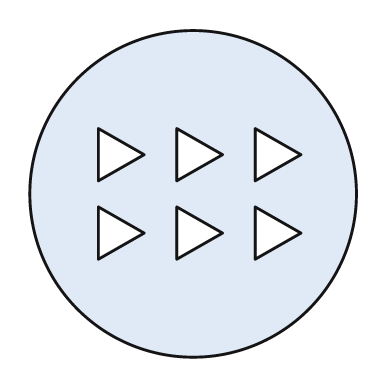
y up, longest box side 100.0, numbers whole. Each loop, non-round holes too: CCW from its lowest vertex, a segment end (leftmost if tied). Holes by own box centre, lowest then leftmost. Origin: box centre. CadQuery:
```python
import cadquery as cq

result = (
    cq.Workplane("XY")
    .moveTo(0.0, 0.0)
    .circle(50.0)
    .moveTo(-29.0, -20.0)
    .lineTo(-15.0, -12.0)
    .lineTo(-29.0, -4.0)
    .close()
    .moveTo(-5.0, -20.0)
    .lineTo(9.0, -12.0)
    .lineTo(-5.0, -4.0)
    .close()
    .moveTo(19.0, -20.0)
    .lineTo(33.0, -12.0)
    .lineTo(19.0, -4.0)
    .close()
    .moveTo(-29.0, 4.0)
    .lineTo(-15.0, 12.0)
    .lineTo(-29.0, 20.0)
    .close()
    .moveTo(-5.0, 4.0)
    .lineTo(9.0, 12.0)
    .lineTo(-5.0, 20.0)
    .close()
    .moveTo(19.0, 4.0)
    .lineTo(33.0, 12.0)
    .lineTo(19.0, 20.0)
    .close()
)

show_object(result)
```